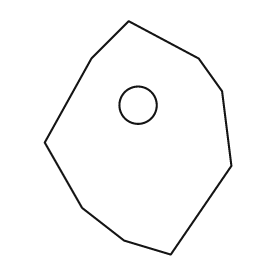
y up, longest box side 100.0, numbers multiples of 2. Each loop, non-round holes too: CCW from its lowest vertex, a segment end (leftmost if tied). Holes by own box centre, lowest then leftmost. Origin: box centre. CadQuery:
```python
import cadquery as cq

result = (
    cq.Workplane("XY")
    .moveTo(14.0, -50.0)
    .lineTo(40.0, -12.0)
    .lineTo(36.0, 20.0)
    .lineTo(26.0, 34.0)
    .lineTo(-4.0, 50.0)
    .lineTo(-20.0, 34.0)
    .lineTo(-40.0, -2.0)
    .lineTo(-24.0, -30.0)
    .lineTo(-6.0, -44.0)
    .close()
    .moveTo(0.0, 14.0)
    .circle(8.0)
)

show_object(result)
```